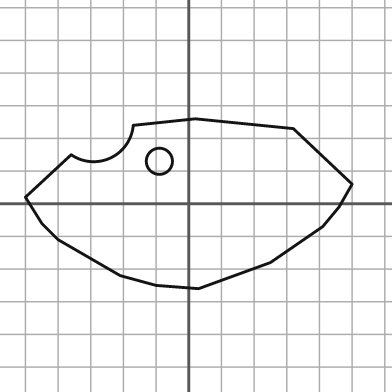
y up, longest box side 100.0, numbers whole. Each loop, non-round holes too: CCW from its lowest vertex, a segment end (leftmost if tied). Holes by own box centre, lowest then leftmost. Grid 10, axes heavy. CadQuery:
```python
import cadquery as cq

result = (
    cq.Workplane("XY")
    .moveTo(3.0, -26.0)
    .lineTo(25.0, -18.0)
    .lineTo(41.0, -7.0)
    .lineTo(46.0, -1.0)
    .lineTo(50.0, 6.0)
    .lineTo(32.0, 23.0)
    .lineTo(2.0, 26.0)
    .lineTo(-17.0, 24.0)
    .threePointArc((-24.0, 14.0), (-36.0, 15.0))
    .lineTo(-50.0, 2.0)
    .lineTo(-45.0, -6.0)
    .lineTo(-40.0, -11.0)
    .lineTo(-21.0, -22.0)
    .lineTo(-10.0, -25.0)
    .close()
    .moveTo(-9.0, 13.0)
    .circle(4.0)
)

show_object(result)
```